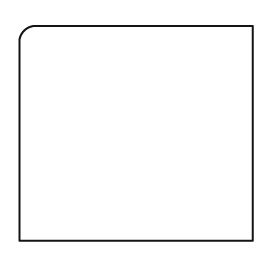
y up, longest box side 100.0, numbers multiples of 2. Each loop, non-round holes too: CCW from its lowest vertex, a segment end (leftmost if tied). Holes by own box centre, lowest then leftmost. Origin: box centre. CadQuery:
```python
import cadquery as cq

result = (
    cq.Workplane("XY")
    .moveTo(-50.0, -46.0)
    .lineTo(50.0, -46.0)
    .lineTo(50.0, 46.0)
    .lineTo(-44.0, 46.0)
    .threePointArc((-48.0, 44.0), (-50.0, 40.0))
    .close()
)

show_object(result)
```